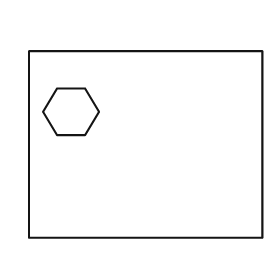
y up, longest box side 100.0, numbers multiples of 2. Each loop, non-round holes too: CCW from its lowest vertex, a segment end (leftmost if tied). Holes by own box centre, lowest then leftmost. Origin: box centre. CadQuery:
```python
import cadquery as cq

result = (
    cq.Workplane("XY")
    .moveTo(-50.0, -40.0)
    .lineTo(50.0, -40.0)
    .lineTo(50.0, 40.0)
    .lineTo(-50.0, 40.0)
    .close()
    .moveTo(-38.0, 4.0)
    .lineTo(-26.0, 4.0)
    .lineTo(-20.0, 14.0)
    .lineTo(-26.0, 24.0)
    .lineTo(-38.0, 24.0)
    .lineTo(-44.0, 14.0)
    .close()
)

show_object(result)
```